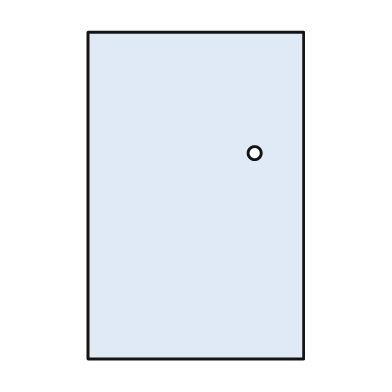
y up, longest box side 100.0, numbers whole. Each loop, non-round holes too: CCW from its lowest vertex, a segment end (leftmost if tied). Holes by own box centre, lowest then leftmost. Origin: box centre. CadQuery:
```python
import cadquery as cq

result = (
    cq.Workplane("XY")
    .moveTo(-33.0, -50.0)
    .lineTo(33.0, -50.0)
    .lineTo(33.0, 50.0)
    .lineTo(-33.0, 50.0)
    .close()
    .moveTo(18.0, 13.0)
    .circle(2.0)
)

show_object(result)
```